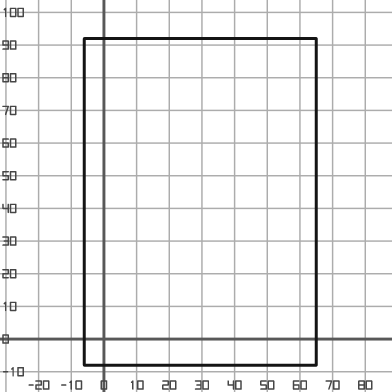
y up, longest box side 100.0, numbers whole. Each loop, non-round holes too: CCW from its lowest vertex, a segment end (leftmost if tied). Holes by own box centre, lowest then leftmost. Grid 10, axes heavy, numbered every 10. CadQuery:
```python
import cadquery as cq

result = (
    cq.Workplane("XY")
    .moveTo(-6.0, -8.0)
    .lineTo(65.0, -8.0)
    .lineTo(65.0, 92.0)
    .lineTo(-6.0, 92.0)
    .close()
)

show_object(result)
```